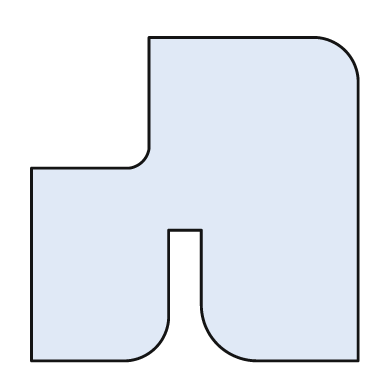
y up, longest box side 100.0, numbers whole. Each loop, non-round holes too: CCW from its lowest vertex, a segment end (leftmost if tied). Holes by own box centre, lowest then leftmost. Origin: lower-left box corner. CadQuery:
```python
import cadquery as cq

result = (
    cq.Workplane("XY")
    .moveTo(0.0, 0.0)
    .lineTo(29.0, 0.0)
    .threePointArc((38.0, 4.0), (42.0, 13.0))
    .lineTo(42.0, 40.0)
    .lineTo(52.0, 40.0)
    .lineTo(52.0, 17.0)
    .threePointArc((57.0, 5.0), (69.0, 0.0))
    .lineTo(100.0, 0.0)
    .lineTo(100.0, 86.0)
    .threePointArc((96.0, 95.0), (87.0, 99.0))
    .lineTo(36.0, 99.0)
    .lineTo(36.0, 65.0)
    .threePointArc((34.0, 61.0), (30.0, 59.0))
    .lineTo(0.0, 59.0)
    .close()
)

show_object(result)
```